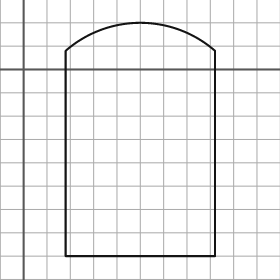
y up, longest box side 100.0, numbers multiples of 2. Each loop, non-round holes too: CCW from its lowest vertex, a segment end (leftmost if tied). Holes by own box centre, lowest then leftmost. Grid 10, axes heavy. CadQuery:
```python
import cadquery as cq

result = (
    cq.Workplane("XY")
    .moveTo(18.0, -80.0)
    .lineTo(82.0, -80.0)
    .lineTo(82.0, 8.0)
    .threePointArc((50.0, 20.0), (18.0, 8.0))
    .close()
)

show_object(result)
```